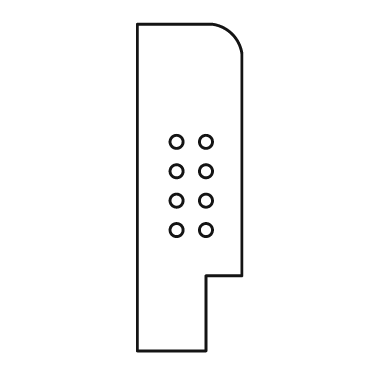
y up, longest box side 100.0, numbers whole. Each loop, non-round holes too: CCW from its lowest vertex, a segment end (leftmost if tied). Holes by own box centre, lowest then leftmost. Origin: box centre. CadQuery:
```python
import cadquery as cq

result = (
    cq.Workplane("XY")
    .moveTo(-16.0, -50.0)
    .lineTo(5.0, -50.0)
    .lineTo(5.0, -27.0)
    .lineTo(16.0, -27.0)
    .lineTo(16.0, 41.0)
    .threePointArc((13.0, 47.0), (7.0, 50.0))
    .lineTo(-16.0, 50.0)
    .close()
    .moveTo(-4.0, -13.0)
    .circle(2.0)
    .moveTo(5.0, -13.0)
    .circle(2.0)
    .moveTo(-4.0, -4.0)
    .circle(2.0)
    .moveTo(5.0, -4.0)
    .circle(2.0)
    .moveTo(-4.0, 5.0)
    .circle(2.0)
    .moveTo(5.0, 5.0)
    .circle(2.0)
    .moveTo(-4.0, 14.0)
    .circle(2.0)
    .moveTo(5.0, 14.0)
    .circle(2.0)
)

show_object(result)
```